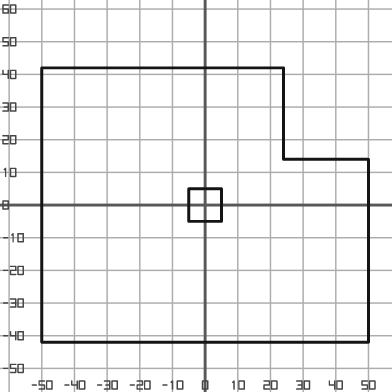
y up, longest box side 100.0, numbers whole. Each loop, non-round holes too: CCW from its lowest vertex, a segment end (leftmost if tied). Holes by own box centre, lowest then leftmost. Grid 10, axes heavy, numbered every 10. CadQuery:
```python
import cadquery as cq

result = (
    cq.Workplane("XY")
    .moveTo(-50.0, -42.0)
    .lineTo(50.0, -42.0)
    .lineTo(50.0, 14.0)
    .lineTo(24.0, 14.0)
    .lineTo(24.0, 42.0)
    .lineTo(-50.0, 42.0)
    .close()
    .moveTo(-5.0, -5.0)
    .lineTo(5.0, -5.0)
    .lineTo(5.0, 5.0)
    .lineTo(-5.0, 5.0)
    .close()
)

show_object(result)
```